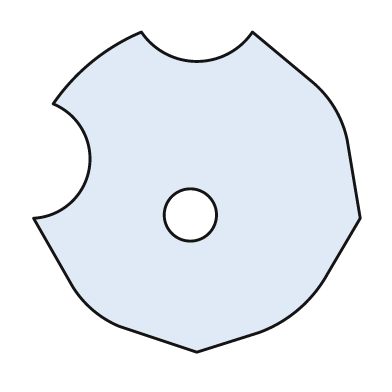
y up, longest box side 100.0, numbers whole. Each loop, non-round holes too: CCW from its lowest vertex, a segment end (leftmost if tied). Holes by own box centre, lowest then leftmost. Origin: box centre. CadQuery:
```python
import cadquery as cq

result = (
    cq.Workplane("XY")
    .moveTo(0.0, -49.0)
    .lineTo(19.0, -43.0)
    .threePointArc((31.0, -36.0), (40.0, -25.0))
    .lineTo(50.0, -8.0)
    .lineTo(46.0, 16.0)
    .threePointArc((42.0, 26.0), (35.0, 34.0))
    .lineTo(17.0, 49.0)
    .threePointArc((0.0, 40.0), (-17.0, 49.0))
    .threePointArc((-32.0, 40.0), (-44.0, 27.0))
    .threePointArc((-33.0, 7.0), (-50.0, -8.0))
    .lineTo(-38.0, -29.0)
    .threePointArc((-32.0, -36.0), (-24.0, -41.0))
    .close()
    .moveTo(-2.0, -7.0)
    .circle(8.0)
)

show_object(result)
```